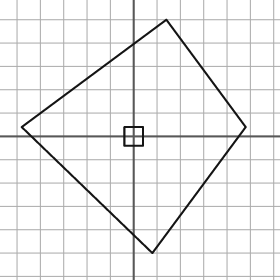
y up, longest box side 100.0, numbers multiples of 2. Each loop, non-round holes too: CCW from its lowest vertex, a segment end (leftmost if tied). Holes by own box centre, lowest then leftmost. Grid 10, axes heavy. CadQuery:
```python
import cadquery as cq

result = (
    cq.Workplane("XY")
    .moveTo(8.0, -50.0)
    .lineTo(48.0, 4.0)
    .lineTo(14.0, 50.0)
    .lineTo(-48.0, 4.0)
    .close()
    .moveTo(-4.0, -4.0)
    .lineTo(4.0, -4.0)
    .lineTo(4.0, 4.0)
    .lineTo(-4.0, 4.0)
    .close()
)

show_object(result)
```